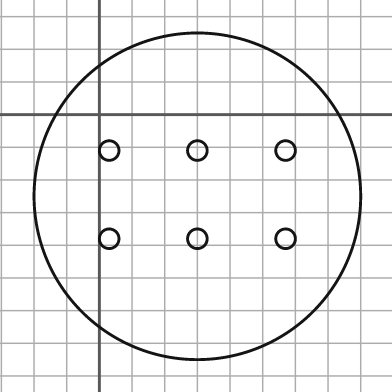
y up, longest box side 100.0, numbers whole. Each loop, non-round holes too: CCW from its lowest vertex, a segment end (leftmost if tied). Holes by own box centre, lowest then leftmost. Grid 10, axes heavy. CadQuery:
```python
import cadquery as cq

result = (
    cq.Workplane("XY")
    .moveTo(30.0, -25.0)
    .circle(50.0)
    .moveTo(3.0, -38.0)
    .circle(3.0)
    .moveTo(30.0, -38.0)
    .circle(3.0)
    .moveTo(57.0, -38.0)
    .circle(3.0)
    .moveTo(3.0, -11.0)
    .circle(3.0)
    .moveTo(30.0, -11.0)
    .circle(3.0)
    .moveTo(57.0, -11.0)
    .circle(3.0)
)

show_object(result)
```